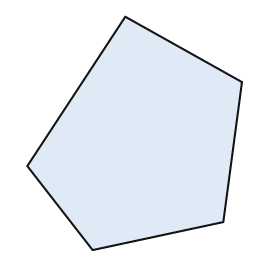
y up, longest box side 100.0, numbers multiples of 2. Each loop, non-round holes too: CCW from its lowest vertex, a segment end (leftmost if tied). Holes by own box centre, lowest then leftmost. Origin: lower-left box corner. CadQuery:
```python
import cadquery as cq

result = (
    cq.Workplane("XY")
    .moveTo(28.0, 0.0)
    .lineTo(84.0, 12.0)
    .lineTo(92.0, 72.0)
    .lineTo(42.0, 100.0)
    .lineTo(0.0, 36.0)
    .close()
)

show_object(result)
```